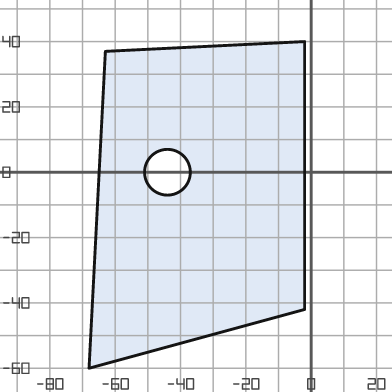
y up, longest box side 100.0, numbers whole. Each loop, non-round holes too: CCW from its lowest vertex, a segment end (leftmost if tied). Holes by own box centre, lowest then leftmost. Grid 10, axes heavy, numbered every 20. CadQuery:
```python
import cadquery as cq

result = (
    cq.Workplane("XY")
    .moveTo(-68.0, -60.0)
    .lineTo(-2.0, -42.0)
    .lineTo(-2.0, 40.0)
    .lineTo(-63.0, 37.0)
    .close()
    .moveTo(-44.0, 0.0)
    .circle(7.0)
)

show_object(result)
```